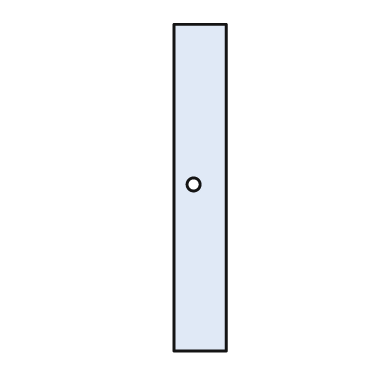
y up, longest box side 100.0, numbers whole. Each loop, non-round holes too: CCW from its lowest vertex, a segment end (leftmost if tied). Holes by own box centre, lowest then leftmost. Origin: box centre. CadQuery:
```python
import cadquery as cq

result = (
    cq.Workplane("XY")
    .moveTo(-8.0, -50.0)
    .lineTo(8.0, -50.0)
    .lineTo(8.0, 50.0)
    .lineTo(-8.0, 50.0)
    .close()
    .moveTo(-2.0, 1.0)
    .circle(2.0)
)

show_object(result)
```